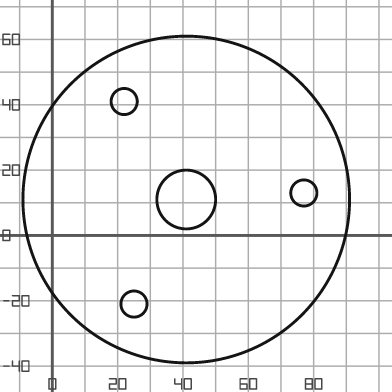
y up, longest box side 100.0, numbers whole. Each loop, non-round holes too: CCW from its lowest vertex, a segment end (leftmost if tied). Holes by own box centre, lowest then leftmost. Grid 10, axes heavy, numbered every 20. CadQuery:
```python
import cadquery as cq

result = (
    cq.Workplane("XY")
    .moveTo(41.0, 11.0)
    .circle(50.0)
    .moveTo(25.0, -21.0)
    .circle(4.0)
    .moveTo(41.0, 11.0)
    .circle(9.0)
    .moveTo(77.0, 13.0)
    .circle(4.0)
    .moveTo(22.0, 41.0)
    .circle(4.0)
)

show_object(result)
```